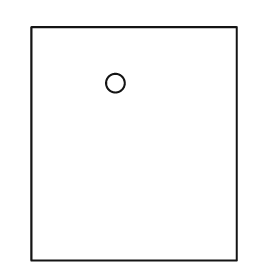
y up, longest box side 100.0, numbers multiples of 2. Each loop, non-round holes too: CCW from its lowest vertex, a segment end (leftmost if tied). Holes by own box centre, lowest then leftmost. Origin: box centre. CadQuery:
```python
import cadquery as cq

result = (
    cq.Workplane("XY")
    .moveTo(-44.0, -50.0)
    .lineTo(44.0, -50.0)
    .lineTo(44.0, 50.0)
    .lineTo(-44.0, 50.0)
    .close()
    .moveTo(-8.0, 26.0)
    .circle(4.0)
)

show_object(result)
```